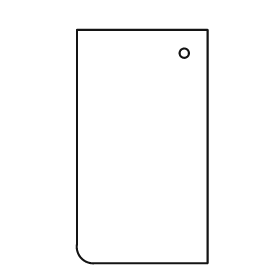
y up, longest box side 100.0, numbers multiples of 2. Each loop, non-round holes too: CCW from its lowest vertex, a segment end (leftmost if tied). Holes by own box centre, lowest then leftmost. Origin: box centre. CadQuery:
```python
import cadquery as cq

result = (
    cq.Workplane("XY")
    .moveTo(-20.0, -50.0)
    .lineTo(28.0, -50.0)
    .lineTo(28.0, 50.0)
    .lineTo(-28.0, 50.0)
    .lineTo(-28.0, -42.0)
    .threePointArc((-26.0, -48.0), (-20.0, -50.0))
    .close()
    .moveTo(18.0, 40.0)
    .circle(2.0)
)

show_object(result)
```